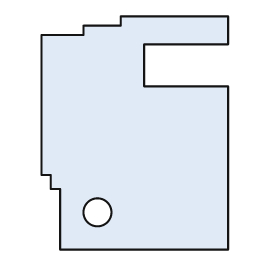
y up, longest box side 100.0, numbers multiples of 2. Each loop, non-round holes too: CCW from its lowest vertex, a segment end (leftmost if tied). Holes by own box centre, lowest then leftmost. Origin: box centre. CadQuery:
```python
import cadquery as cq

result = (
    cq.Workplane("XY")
    .moveTo(-32.0, -50.0)
    .lineTo(40.0, -50.0)
    .lineTo(40.0, 20.0)
    .lineTo(4.0, 20.0)
    .lineTo(4.0, 38.0)
    .lineTo(40.0, 38.0)
    .lineTo(40.0, 50.0)
    .lineTo(-6.0, 50.0)
    .lineTo(-6.0, 46.0)
    .lineTo(-22.0, 46.0)
    .lineTo(-22.0, 42.0)
    .lineTo(-40.0, 42.0)
    .lineTo(-40.0, -18.0)
    .lineTo(-36.0, -18.0)
    .lineTo(-36.0, -24.0)
    .lineTo(-32.0, -24.0)
    .close()
    .moveTo(-16.0, -34.0)
    .circle(6.0)
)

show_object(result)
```